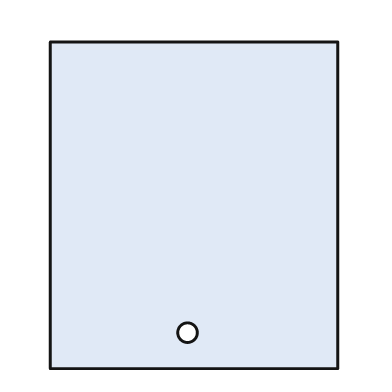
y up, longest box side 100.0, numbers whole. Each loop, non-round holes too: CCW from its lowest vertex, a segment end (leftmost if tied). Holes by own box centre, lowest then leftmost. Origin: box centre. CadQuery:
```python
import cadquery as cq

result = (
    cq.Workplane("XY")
    .moveTo(-44.0, -50.0)
    .lineTo(44.0, -50.0)
    .lineTo(44.0, 50.0)
    .lineTo(-44.0, 50.0)
    .close()
    .moveTo(-2.0, -39.0)
    .circle(3.0)
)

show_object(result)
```